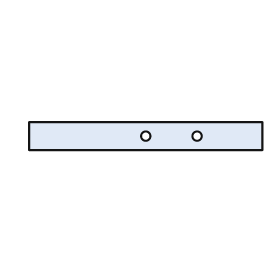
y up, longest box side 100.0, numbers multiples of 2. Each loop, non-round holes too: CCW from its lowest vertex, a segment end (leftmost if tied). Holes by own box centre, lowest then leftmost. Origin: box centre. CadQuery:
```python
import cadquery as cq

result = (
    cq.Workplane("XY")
    .moveTo(-50.0, -6.0)
    .lineTo(50.0, -6.0)
    .lineTo(50.0, 6.0)
    .lineTo(-50.0, 6.0)
    .close()
    .moveTo(0.0, 0.0)
    .circle(2.0)
    .moveTo(22.0, 0.0)
    .circle(2.0)
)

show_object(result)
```